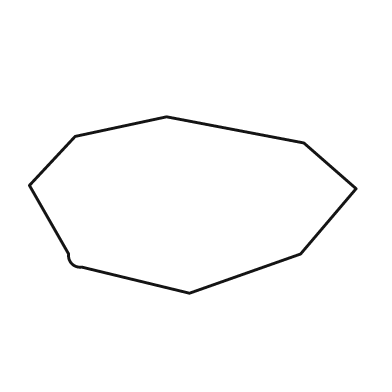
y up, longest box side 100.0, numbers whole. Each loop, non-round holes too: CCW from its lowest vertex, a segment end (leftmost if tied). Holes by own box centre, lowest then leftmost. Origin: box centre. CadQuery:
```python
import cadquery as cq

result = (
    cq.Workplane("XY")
    .moveTo(-1.0, -27.0)
    .lineTo(33.0, -15.0)
    .lineTo(50.0, 5.0)
    .lineTo(34.0, 19.0)
    .lineTo(-8.0, 27.0)
    .lineTo(-36.0, 21.0)
    .lineTo(-50.0, 6.0)
    .lineTo(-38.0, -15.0)
    .threePointArc((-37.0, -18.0), (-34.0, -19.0))
    .close()
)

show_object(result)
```